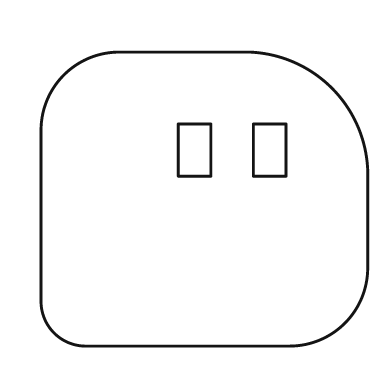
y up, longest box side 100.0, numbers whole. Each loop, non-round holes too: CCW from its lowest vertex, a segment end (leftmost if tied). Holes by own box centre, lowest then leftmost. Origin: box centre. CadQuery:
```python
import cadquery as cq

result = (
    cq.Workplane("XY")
    .moveTo(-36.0, -45.0)
    .lineTo(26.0, -45.0)
    .threePointArc((43.0, -38.0), (50.0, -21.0))
    .lineTo(50.0, 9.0)
    .threePointArc((39.0, 34.0), (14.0, 45.0))
    .lineTo(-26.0, 45.0)
    .threePointArc((-43.0, 38.0), (-50.0, 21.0))
    .lineTo(-50.0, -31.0)
    .threePointArc((-46.0, -41.0), (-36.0, -45.0))
    .close()
    .moveTo(-8.0, 7.0)
    .lineTo(2.0, 7.0)
    .lineTo(2.0, 23.0)
    .lineTo(-8.0, 23.0)
    .close()
    .moveTo(15.0, 7.0)
    .lineTo(25.0, 7.0)
    .lineTo(25.0, 23.0)
    .lineTo(15.0, 23.0)
    .close()
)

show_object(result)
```